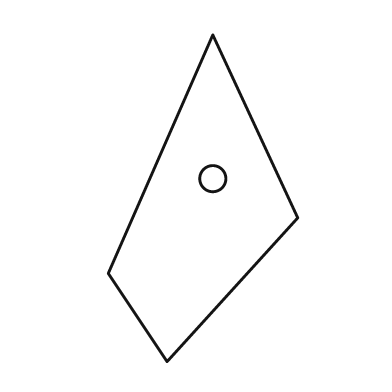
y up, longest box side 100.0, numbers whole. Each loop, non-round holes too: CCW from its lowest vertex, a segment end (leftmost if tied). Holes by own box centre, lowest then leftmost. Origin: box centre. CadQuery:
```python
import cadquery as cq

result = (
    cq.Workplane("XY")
    .moveTo(-11.0, -50.0)
    .lineTo(29.0, -6.0)
    .lineTo(3.0, 50.0)
    .lineTo(-29.0, -23.0)
    .close()
    .moveTo(3.0, 6.0)
    .circle(4.0)
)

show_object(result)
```